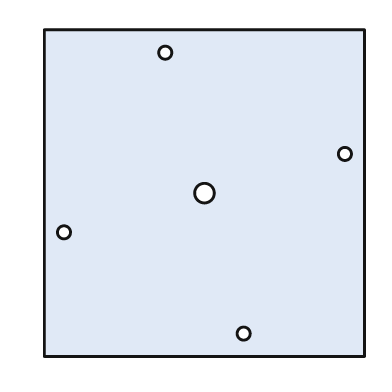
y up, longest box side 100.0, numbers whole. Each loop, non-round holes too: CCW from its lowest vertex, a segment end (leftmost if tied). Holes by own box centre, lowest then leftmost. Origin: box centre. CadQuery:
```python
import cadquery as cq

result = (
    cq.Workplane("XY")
    .moveTo(-49.0, -50.0)
    .lineTo(49.0, -50.0)
    .lineTo(49.0, 50.0)
    .lineTo(-49.0, 50.0)
    .close()
    .moveTo(12.0, -43.0)
    .circle(2.0)
    .moveTo(-43.0, -12.0)
    .circle(2.0)
    .moveTo(0.0, 0.0)
    .circle(3.0)
    .moveTo(43.0, 12.0)
    .circle(2.0)
    .moveTo(-12.0, 43.0)
    .circle(2.0)
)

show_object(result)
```